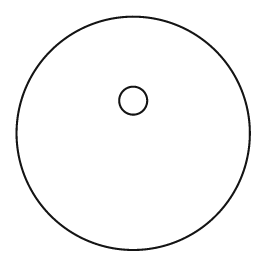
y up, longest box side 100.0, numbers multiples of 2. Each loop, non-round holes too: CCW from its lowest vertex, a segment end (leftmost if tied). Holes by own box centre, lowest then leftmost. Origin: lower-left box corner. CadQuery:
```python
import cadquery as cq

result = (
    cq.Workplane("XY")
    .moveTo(50.0, 50.0)
    .circle(50.0)
    .moveTo(50.0, 64.0)
    .circle(6.0)
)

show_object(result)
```